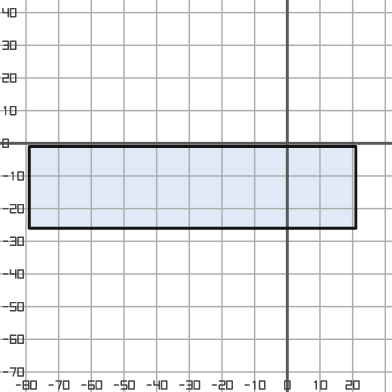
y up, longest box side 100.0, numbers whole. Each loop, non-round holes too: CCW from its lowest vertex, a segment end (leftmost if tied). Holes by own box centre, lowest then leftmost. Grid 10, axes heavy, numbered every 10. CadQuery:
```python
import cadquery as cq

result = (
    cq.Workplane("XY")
    .moveTo(-79.0, -26.0)
    .lineTo(21.0, -26.0)
    .lineTo(21.0, -1.0)
    .lineTo(-79.0, -1.0)
    .close()
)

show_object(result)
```